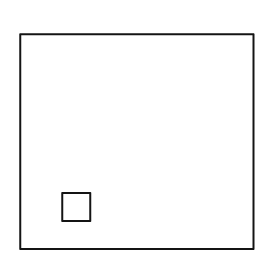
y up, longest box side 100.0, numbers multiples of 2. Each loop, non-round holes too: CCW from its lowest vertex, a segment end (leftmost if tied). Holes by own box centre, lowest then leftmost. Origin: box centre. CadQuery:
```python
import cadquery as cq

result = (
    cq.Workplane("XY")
    .moveTo(-50.0, -46.0)
    .lineTo(50.0, -46.0)
    .lineTo(50.0, 46.0)
    .lineTo(-50.0, 46.0)
    .close()
    .moveTo(-32.0, -34.0)
    .lineTo(-20.0, -34.0)
    .lineTo(-20.0, -22.0)
    .lineTo(-32.0, -22.0)
    .close()
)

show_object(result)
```